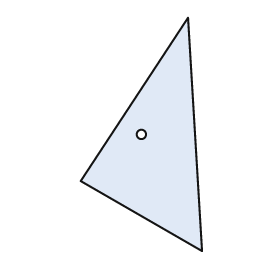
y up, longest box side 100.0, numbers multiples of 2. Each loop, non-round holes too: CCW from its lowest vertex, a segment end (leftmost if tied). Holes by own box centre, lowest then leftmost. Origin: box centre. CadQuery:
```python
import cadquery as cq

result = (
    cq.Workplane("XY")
    .moveTo(26.0, -50.0)
    .lineTo(20.0, 50.0)
    .lineTo(-26.0, -20.0)
    .close()
    .moveTo(0.0, 0.0)
    .circle(2.0)
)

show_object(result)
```